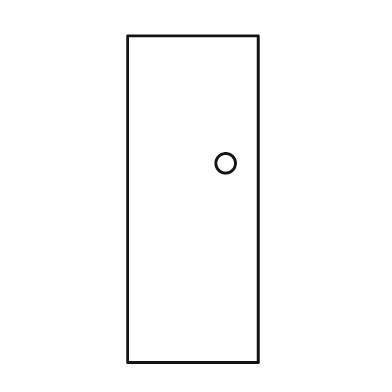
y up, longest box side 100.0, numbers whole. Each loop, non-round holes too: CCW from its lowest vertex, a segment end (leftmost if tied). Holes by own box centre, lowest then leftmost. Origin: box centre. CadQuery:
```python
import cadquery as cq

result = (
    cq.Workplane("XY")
    .moveTo(-20.0, -50.0)
    .lineTo(20.0, -50.0)
    .lineTo(20.0, 50.0)
    .lineTo(-20.0, 50.0)
    .close()
    .moveTo(10.0, 11.0)
    .circle(3.0)
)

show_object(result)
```